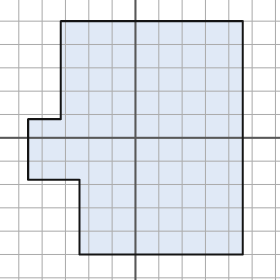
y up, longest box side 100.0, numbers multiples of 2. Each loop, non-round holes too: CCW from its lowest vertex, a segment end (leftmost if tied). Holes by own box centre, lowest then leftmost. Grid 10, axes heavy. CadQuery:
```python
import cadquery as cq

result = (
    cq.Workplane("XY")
    .moveTo(-24.0, -50.0)
    .lineTo(46.0, -50.0)
    .lineTo(46.0, 50.0)
    .lineTo(-32.0, 50.0)
    .lineTo(-32.0, 8.0)
    .lineTo(-46.0, 8.0)
    .lineTo(-46.0, -18.0)
    .lineTo(-24.0, -18.0)
    .close()
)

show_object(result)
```